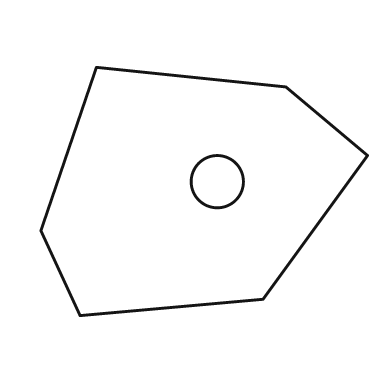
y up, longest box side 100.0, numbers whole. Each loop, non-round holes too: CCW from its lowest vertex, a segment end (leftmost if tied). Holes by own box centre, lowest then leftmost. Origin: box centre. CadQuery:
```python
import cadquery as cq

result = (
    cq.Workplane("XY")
    .moveTo(-38.0, -38.0)
    .lineTo(18.0, -33.0)
    .lineTo(50.0, 11.0)
    .lineTo(25.0, 32.0)
    .lineTo(-33.0, 38.0)
    .lineTo(-50.0, -12.0)
    .close()
    .moveTo(4.0, 3.0)
    .circle(8.0)
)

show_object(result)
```